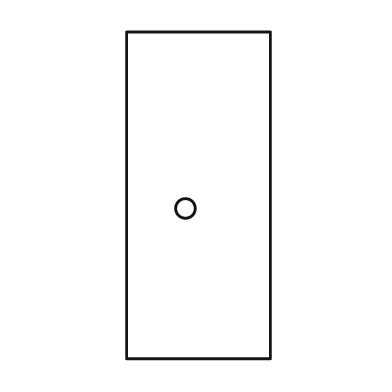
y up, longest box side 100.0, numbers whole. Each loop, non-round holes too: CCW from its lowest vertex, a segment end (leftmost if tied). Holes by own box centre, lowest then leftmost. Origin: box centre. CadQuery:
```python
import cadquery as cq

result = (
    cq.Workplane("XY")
    .moveTo(-22.0, -50.0)
    .lineTo(22.0, -50.0)
    .lineTo(22.0, 50.0)
    .lineTo(-22.0, 50.0)
    .close()
    .moveTo(-4.0, -4.0)
    .circle(3.0)
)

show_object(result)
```